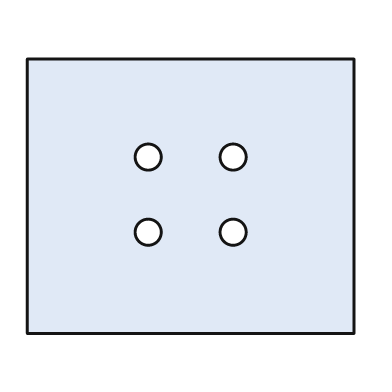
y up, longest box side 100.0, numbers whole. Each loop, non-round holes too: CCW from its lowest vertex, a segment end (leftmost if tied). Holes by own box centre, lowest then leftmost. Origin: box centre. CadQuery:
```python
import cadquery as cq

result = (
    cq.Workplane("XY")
    .moveTo(-50.0, -42.0)
    .lineTo(50.0, -42.0)
    .lineTo(50.0, 42.0)
    .lineTo(-50.0, 42.0)
    .close()
    .moveTo(-13.0, -11.0)
    .circle(4.0)
    .moveTo(13.0, -11.0)
    .circle(4.0)
    .moveTo(-13.0, 12.0)
    .circle(4.0)
    .moveTo(13.0, 12.0)
    .circle(4.0)
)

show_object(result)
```